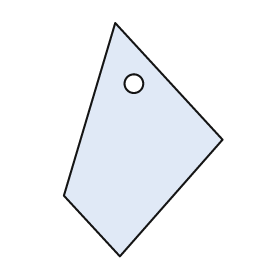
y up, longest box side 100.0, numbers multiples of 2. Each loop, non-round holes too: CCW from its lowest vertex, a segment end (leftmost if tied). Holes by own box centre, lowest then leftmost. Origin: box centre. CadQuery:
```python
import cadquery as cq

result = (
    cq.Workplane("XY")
    .moveTo(-10.0, -50.0)
    .lineTo(34.0, 0.0)
    .lineTo(-12.0, 50.0)
    .lineTo(-34.0, -24.0)
    .close()
    .moveTo(-4.0, 24.0)
    .circle(4.0)
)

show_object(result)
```